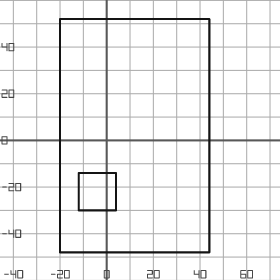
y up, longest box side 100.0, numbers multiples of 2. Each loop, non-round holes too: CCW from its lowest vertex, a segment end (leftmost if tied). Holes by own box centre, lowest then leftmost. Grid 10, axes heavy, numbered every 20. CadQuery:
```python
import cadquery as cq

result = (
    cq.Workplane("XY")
    .moveTo(-20.0, -48.0)
    .lineTo(44.0, -48.0)
    .lineTo(44.0, 52.0)
    .lineTo(-20.0, 52.0)
    .close()
    .moveTo(-12.0, -30.0)
    .lineTo(4.0, -30.0)
    .lineTo(4.0, -14.0)
    .lineTo(-12.0, -14.0)
    .close()
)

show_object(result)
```